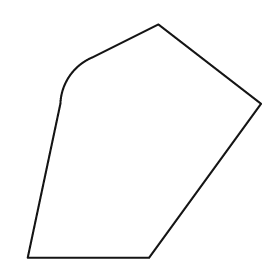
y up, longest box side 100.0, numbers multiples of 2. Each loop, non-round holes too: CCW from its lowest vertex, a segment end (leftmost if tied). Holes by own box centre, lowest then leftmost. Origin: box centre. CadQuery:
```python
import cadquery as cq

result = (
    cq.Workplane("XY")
    .moveTo(-50.0, -50.0)
    .lineTo(2.0, -50.0)
    .lineTo(50.0, 16.0)
    .lineTo(6.0, 50.0)
    .lineTo(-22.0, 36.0)
    .threePointArc((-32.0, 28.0), (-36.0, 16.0))
    .close()
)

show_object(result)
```